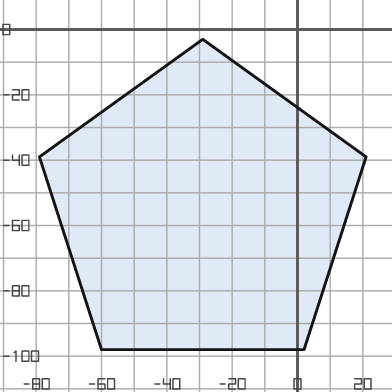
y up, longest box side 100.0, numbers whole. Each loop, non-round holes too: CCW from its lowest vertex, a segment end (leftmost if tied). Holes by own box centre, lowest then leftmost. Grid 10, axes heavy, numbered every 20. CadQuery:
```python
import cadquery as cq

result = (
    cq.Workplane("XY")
    .moveTo(-60.0, -98.0)
    .lineTo(2.0, -98.0)
    .lineTo(21.0, -39.0)
    .lineTo(-29.0, -3.0)
    .lineTo(-79.0, -39.0)
    .close()
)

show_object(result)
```